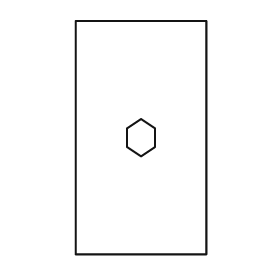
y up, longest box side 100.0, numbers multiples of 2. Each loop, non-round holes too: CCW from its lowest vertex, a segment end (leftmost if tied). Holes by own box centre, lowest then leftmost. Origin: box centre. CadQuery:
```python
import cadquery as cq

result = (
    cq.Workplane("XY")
    .moveTo(-28.0, -50.0)
    .lineTo(28.0, -50.0)
    .lineTo(28.0, 50.0)
    .lineTo(-28.0, 50.0)
    .close()
    .moveTo(0.0, -8.0)
    .lineTo(6.0, -4.0)
    .lineTo(6.0, 4.0)
    .lineTo(0.0, 8.0)
    .lineTo(-6.0, 4.0)
    .lineTo(-6.0, -4.0)
    .close()
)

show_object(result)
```